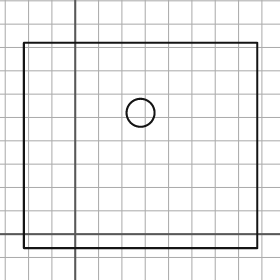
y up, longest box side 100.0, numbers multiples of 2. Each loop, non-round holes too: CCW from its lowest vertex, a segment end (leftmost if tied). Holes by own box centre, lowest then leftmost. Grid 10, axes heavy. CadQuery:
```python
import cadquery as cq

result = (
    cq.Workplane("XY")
    .moveTo(-22.0, -6.0)
    .lineTo(78.0, -6.0)
    .lineTo(78.0, 82.0)
    .lineTo(-22.0, 82.0)
    .close()
    .moveTo(28.0, 52.0)
    .circle(6.0)
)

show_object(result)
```